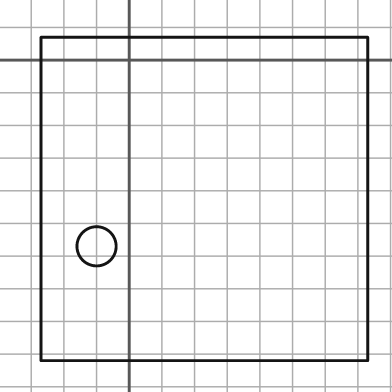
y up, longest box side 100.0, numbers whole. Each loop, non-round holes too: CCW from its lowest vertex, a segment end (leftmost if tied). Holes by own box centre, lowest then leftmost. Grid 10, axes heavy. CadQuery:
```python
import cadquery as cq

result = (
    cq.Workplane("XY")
    .moveTo(-27.0, -92.0)
    .lineTo(73.0, -92.0)
    .lineTo(73.0, 7.0)
    .lineTo(-27.0, 7.0)
    .close()
    .moveTo(-10.0, -57.0)
    .circle(6.0)
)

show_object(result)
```